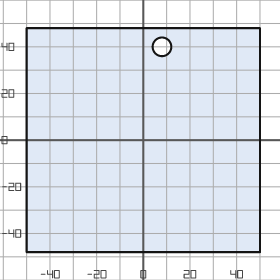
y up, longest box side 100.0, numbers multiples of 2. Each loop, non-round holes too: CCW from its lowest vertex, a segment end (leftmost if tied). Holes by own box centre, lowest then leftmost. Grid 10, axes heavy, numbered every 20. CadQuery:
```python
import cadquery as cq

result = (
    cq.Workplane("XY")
    .moveTo(-50.0, -48.0)
    .lineTo(50.0, -48.0)
    .lineTo(50.0, 48.0)
    .lineTo(-50.0, 48.0)
    .close()
    .moveTo(8.0, 40.0)
    .circle(4.0)
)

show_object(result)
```